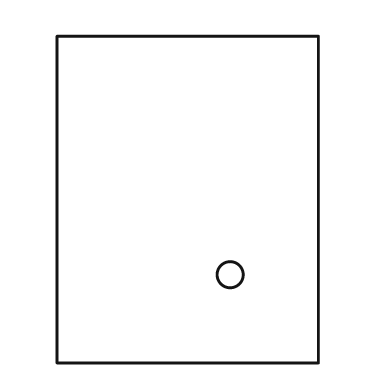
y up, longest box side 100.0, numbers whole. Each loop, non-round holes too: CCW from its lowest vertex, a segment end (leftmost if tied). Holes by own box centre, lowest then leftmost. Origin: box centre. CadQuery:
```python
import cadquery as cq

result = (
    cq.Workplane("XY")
    .moveTo(-40.0, -50.0)
    .lineTo(40.0, -50.0)
    .lineTo(40.0, 50.0)
    .lineTo(-40.0, 50.0)
    .close()
    .moveTo(13.0, -23.0)
    .circle(4.0)
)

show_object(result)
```